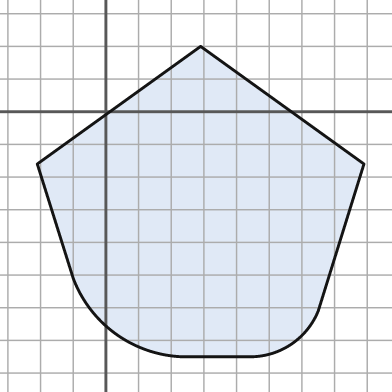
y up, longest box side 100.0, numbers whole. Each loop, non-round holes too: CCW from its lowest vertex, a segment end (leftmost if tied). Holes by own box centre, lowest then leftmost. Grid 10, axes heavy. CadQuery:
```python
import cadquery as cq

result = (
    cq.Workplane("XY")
    .moveTo(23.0, -75.0)
    .lineTo(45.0, -75.0)
    .threePointArc((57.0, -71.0), (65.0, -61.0))
    .lineTo(79.0, -16.0)
    .lineTo(29.0, 20.0)
    .lineTo(-21.0, -16.0)
    .lineTo(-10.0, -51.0)
    .threePointArc((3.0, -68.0), (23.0, -75.0))
    .close()
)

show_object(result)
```